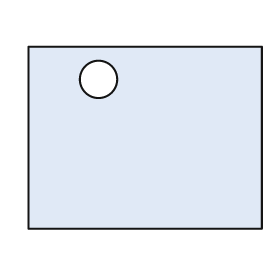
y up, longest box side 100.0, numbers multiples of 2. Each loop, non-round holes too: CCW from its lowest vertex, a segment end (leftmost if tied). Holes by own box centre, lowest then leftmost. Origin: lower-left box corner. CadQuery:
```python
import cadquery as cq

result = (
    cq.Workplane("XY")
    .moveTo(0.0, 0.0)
    .lineTo(100.0, 0.0)
    .lineTo(100.0, 78.0)
    .lineTo(0.0, 78.0)
    .close()
    .moveTo(30.0, 64.0)
    .circle(8.0)
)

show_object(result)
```